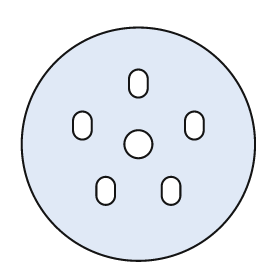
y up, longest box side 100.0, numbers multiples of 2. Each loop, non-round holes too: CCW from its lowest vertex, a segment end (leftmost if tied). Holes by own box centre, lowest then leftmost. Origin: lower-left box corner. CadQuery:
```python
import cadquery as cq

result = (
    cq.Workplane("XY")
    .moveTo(50.0, 50.0)
    .circle(50.0)
    .moveTo(32.0, 28.0)
    .threePointArc((36.0, 24.0), (40.0, 28.0))
    .lineTo(40.0, 32.0)
    .threePointArc((36.0, 36.0), (32.0, 32.0))
    .close()
    .moveTo(60.0, 28.0)
    .threePointArc((64.0, 24.0), (68.0, 28.0))
    .lineTo(68.0, 32.0)
    .threePointArc((64.0, 36.0), (60.0, 32.0))
    .close()
    .moveTo(50.0, 50.0)
    .circle(6.0)
    .moveTo(22.0, 56.0)
    .threePointArc((26.0, 52.0), (30.0, 56.0))
    .lineTo(30.0, 60.0)
    .threePointArc((26.0, 64.0), (22.0, 60.0))
    .close()
    .moveTo(70.0, 56.0)
    .threePointArc((74.0, 52.0), (78.0, 56.0))
    .lineTo(78.0, 60.0)
    .threePointArc((74.0, 64.0), (70.0, 60.0))
    .close()
    .moveTo(46.0, 74.0)
    .threePointArc((50.0, 70.0), (54.0, 74.0))
    .lineTo(54.0, 78.0)
    .threePointArc((50.0, 82.0), (46.0, 78.0))
    .close()
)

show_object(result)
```